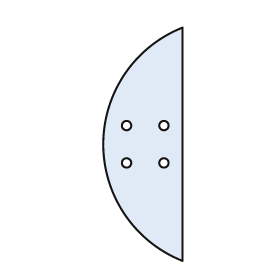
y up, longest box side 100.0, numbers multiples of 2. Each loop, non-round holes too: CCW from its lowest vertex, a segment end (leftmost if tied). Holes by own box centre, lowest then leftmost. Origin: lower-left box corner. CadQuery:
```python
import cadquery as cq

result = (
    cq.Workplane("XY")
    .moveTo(34.0, 0.0)
    .lineTo(34.0, 100.0)
    .threePointArc((0.0, 50.0), (34.0, 0.0))
    .close()
    .moveTo(10.0, 42.0)
    .circle(2.0)
    .moveTo(26.0, 42.0)
    .circle(2.0)
    .moveTo(10.0, 58.0)
    .circle(2.0)
    .moveTo(26.0, 58.0)
    .circle(2.0)
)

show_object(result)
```